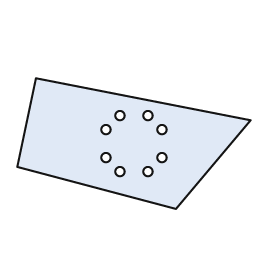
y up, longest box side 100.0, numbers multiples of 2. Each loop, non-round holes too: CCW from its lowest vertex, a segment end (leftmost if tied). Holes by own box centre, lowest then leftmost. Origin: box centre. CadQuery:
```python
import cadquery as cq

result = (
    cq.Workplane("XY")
    .moveTo(18.0, -28.0)
    .lineTo(50.0, 10.0)
    .lineTo(-42.0, 28.0)
    .lineTo(-50.0, -10.0)
    .close()
    .moveTo(-6.0, -12.0)
    .circle(2.0)
    .moveTo(6.0, -12.0)
    .circle(2.0)
    .moveTo(-12.0, -6.0)
    .circle(2.0)
    .moveTo(12.0, -6.0)
    .circle(2.0)
    .moveTo(-12.0, 6.0)
    .circle(2.0)
    .moveTo(12.0, 6.0)
    .circle(2.0)
    .moveTo(-6.0, 12.0)
    .circle(2.0)
    .moveTo(6.0, 12.0)
    .circle(2.0)
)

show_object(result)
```